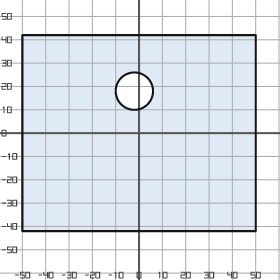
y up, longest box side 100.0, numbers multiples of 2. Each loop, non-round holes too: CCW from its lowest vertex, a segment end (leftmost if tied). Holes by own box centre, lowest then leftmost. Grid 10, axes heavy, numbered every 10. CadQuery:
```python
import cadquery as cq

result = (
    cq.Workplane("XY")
    .moveTo(-50.0, -42.0)
    .lineTo(50.0, -42.0)
    .lineTo(50.0, 42.0)
    .lineTo(-50.0, 42.0)
    .close()
    .moveTo(-2.0, 18.0)
    .circle(8.0)
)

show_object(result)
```